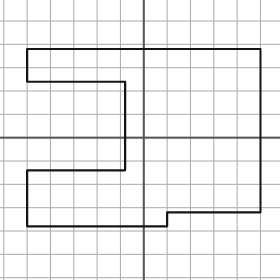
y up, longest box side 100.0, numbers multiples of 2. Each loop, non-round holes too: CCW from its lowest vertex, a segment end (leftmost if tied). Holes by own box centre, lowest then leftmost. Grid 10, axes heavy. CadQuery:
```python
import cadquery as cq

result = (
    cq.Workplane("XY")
    .moveTo(-50.0, -38.0)
    .lineTo(10.0, -38.0)
    .lineTo(10.0, -32.0)
    .lineTo(50.0, -32.0)
    .lineTo(50.0, 38.0)
    .lineTo(-50.0, 38.0)
    .lineTo(-50.0, 24.0)
    .lineTo(-8.0, 24.0)
    .lineTo(-8.0, -14.0)
    .lineTo(-50.0, -14.0)
    .close()
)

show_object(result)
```